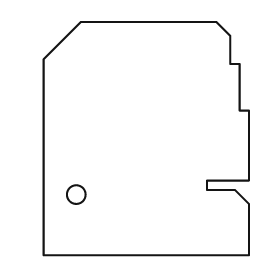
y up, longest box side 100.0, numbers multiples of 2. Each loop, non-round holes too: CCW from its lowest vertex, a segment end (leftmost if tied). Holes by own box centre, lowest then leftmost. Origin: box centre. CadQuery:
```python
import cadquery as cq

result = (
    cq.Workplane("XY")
    .moveTo(-44.0, -50.0)
    .lineTo(44.0, -50.0)
    .lineTo(44.0, -28.0)
    .lineTo(38.0, -22.0)
    .lineTo(26.0, -22.0)
    .lineTo(26.0, -18.0)
    .lineTo(44.0, -18.0)
    .lineTo(44.0, 12.0)
    .lineTo(40.0, 12.0)
    .lineTo(40.0, 32.0)
    .lineTo(36.0, 32.0)
    .lineTo(36.0, 44.0)
    .lineTo(30.0, 50.0)
    .lineTo(-28.0, 50.0)
    .lineTo(-44.0, 34.0)
    .close()
    .moveTo(-30.0, -24.0)
    .circle(4.0)
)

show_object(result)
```